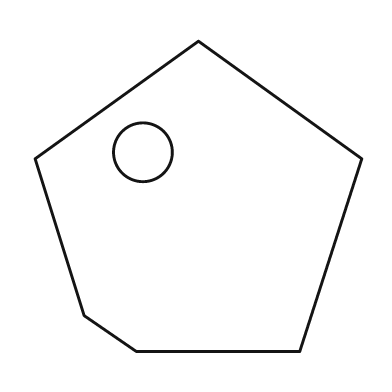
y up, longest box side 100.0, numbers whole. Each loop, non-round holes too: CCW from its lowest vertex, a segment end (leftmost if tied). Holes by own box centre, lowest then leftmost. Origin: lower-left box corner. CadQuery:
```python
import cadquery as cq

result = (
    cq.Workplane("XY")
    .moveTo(31.0, 0.0)
    .lineTo(81.0, 0.0)
    .lineTo(100.0, 59.0)
    .lineTo(50.0, 95.0)
    .lineTo(0.0, 59.0)
    .lineTo(15.0, 11.0)
    .close()
    .moveTo(33.0, 61.0)
    .circle(9.0)
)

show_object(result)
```